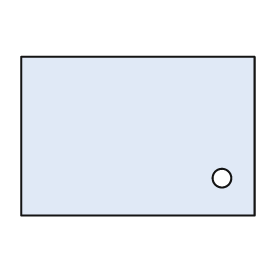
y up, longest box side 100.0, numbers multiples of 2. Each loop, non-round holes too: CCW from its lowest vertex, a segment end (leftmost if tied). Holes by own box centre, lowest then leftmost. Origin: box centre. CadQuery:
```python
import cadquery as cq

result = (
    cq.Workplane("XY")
    .moveTo(-50.0, -34.0)
    .lineTo(50.0, -34.0)
    .lineTo(50.0, 34.0)
    .lineTo(-50.0, 34.0)
    .close()
    .moveTo(36.0, -18.0)
    .circle(4.0)
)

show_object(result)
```